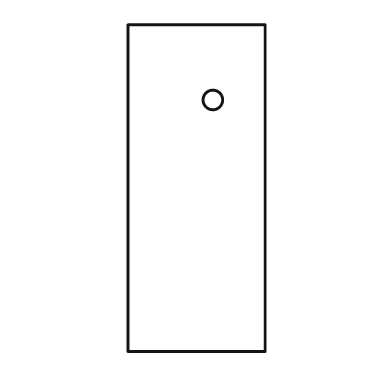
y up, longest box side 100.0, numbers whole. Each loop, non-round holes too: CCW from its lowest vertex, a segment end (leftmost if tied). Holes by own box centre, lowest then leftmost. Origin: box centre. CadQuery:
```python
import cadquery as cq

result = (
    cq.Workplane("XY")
    .moveTo(-21.0, -50.0)
    .lineTo(21.0, -50.0)
    .lineTo(21.0, 50.0)
    .lineTo(-21.0, 50.0)
    .close()
    .moveTo(5.0, 27.0)
    .circle(3.0)
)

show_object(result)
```